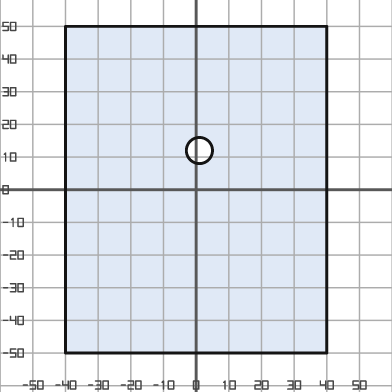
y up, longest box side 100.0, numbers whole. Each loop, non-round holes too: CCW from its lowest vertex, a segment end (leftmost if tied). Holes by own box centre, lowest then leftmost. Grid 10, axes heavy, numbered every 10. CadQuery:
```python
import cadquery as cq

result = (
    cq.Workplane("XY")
    .moveTo(-40.0, -50.0)
    .lineTo(40.0, -50.0)
    .lineTo(40.0, 50.0)
    .lineTo(-40.0, 50.0)
    .close()
    .moveTo(1.0, 12.0)
    .circle(4.0)
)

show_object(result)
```